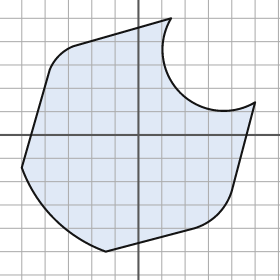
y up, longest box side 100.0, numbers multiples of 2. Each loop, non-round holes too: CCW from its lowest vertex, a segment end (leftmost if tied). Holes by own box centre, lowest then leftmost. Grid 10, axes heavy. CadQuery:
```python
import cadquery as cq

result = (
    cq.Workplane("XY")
    .moveTo(-14.0, -50.0)
    .lineTo(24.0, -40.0)
    .threePointArc((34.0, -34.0), (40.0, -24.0))
    .lineTo(50.0, 14.0)
    .threePointArc((18.0, 18.0), (14.0, 50.0))
    .lineTo(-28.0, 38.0)
    .threePointArc((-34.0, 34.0), (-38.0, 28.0))
    .lineTo(-50.0, -14.0)
    .threePointArc((-36.0, -36.0), (-14.0, -50.0))
    .close()
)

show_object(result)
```